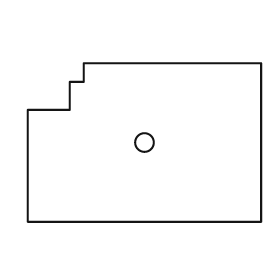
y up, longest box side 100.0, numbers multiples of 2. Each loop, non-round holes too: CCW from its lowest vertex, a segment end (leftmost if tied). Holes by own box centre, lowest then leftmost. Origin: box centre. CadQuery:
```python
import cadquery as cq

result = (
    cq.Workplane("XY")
    .moveTo(-50.0, -34.0)
    .lineTo(50.0, -34.0)
    .lineTo(50.0, 34.0)
    .lineTo(-26.0, 34.0)
    .lineTo(-26.0, 26.0)
    .lineTo(-32.0, 26.0)
    .lineTo(-32.0, 14.0)
    .lineTo(-50.0, 14.0)
    .close()
    .moveTo(0.0, 0.0)
    .circle(4.0)
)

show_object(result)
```